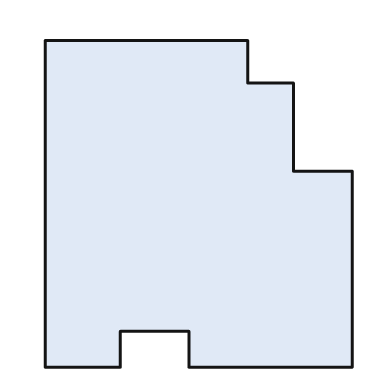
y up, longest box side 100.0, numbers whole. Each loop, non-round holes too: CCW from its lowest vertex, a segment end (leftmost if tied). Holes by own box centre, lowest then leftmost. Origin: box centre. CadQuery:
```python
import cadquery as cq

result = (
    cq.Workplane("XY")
    .moveTo(-47.0, -50.0)
    .lineTo(-24.0, -50.0)
    .lineTo(-24.0, -39.0)
    .lineTo(-3.0, -39.0)
    .lineTo(-3.0, -50.0)
    .lineTo(47.0, -50.0)
    .lineTo(47.0, 10.0)
    .lineTo(29.0, 10.0)
    .lineTo(29.0, 37.0)
    .lineTo(15.0, 37.0)
    .lineTo(15.0, 50.0)
    .lineTo(-47.0, 50.0)
    .close()
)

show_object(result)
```